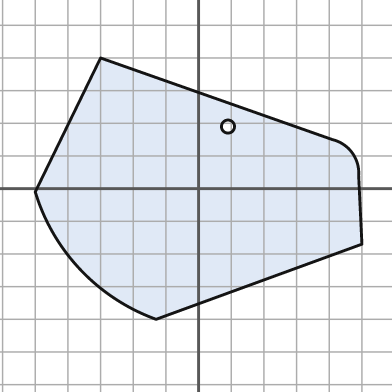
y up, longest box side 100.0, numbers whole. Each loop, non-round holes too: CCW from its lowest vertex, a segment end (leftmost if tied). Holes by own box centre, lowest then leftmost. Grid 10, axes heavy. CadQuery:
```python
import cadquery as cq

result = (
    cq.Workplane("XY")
    .moveTo(-13.0, -40.0)
    .lineTo(50.0, -17.0)
    .lineTo(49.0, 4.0)
    .threePointArc((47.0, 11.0), (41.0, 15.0))
    .lineTo(-30.0, 40.0)
    .lineTo(-50.0, -1.0)
    .threePointArc((-36.0, -25.0), (-13.0, -40.0))
    .close()
    .moveTo(9.0, 19.0)
    .circle(2.0)
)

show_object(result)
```